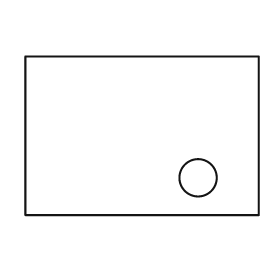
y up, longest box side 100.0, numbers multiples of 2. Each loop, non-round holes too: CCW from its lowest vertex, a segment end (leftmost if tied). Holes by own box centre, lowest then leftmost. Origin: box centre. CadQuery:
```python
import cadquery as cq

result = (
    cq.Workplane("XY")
    .moveTo(-50.0, -34.0)
    .lineTo(50.0, -34.0)
    .lineTo(50.0, 34.0)
    .lineTo(-50.0, 34.0)
    .close()
    .moveTo(24.0, -18.0)
    .circle(8.0)
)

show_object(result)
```